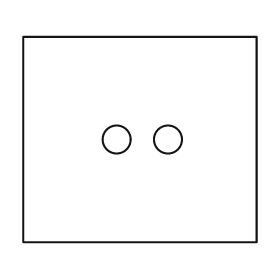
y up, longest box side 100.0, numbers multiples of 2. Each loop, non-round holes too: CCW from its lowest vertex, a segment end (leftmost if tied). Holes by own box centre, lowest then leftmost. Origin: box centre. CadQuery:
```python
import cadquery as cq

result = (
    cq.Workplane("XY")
    .moveTo(-50.0, -44.0)
    .lineTo(50.0, -44.0)
    .lineTo(50.0, 44.0)
    .lineTo(-50.0, 44.0)
    .close()
    .moveTo(-10.0, 0.0)
    .circle(6.0)
    .moveTo(12.0, 0.0)
    .circle(6.0)
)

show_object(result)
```